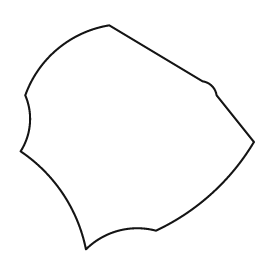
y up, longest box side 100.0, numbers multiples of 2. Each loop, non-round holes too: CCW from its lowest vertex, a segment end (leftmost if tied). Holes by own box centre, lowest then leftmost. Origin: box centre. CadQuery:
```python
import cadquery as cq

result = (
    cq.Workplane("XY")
    .moveTo(-22.0, -48.0)
    .threePointArc((-8.0, -40.0), (8.0, -40.0))
    .threePointArc((32.0, -24.0), (50.0, -2.0))
    .lineTo(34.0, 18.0)
    .threePointArc((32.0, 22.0), (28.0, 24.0))
    .lineTo(-12.0, 48.0)
    .threePointArc((-34.0, 38.0), (-48.0, 18.0))
    .threePointArc((-46.0, 6.0), (-50.0, -6.0))
    .threePointArc((-32.0, -24.0), (-22.0, -48.0))
    .close()
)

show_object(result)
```